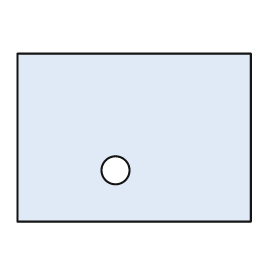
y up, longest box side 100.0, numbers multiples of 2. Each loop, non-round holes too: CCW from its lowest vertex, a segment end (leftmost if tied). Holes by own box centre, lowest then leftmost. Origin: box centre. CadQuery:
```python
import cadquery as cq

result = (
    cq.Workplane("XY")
    .moveTo(-50.0, -36.0)
    .lineTo(50.0, -36.0)
    .lineTo(50.0, 36.0)
    .lineTo(-50.0, 36.0)
    .close()
    .moveTo(-8.0, -14.0)
    .circle(6.0)
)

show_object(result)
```